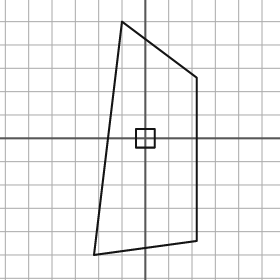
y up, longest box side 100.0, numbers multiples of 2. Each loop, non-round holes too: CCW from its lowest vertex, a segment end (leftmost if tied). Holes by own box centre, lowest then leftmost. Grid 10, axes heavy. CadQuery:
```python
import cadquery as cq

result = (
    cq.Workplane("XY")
    .moveTo(-22.0, -50.0)
    .lineTo(22.0, -44.0)
    .lineTo(22.0, 26.0)
    .lineTo(-10.0, 50.0)
    .close()
    .moveTo(-4.0, -4.0)
    .lineTo(4.0, -4.0)
    .lineTo(4.0, 4.0)
    .lineTo(-4.0, 4.0)
    .close()
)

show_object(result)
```